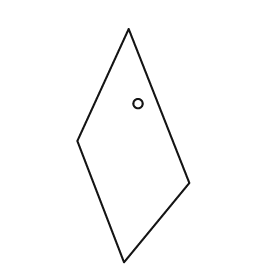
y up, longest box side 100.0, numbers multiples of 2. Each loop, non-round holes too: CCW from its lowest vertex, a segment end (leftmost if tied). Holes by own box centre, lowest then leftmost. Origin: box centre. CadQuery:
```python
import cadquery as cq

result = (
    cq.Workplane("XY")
    .moveTo(-4.0, -50.0)
    .lineTo(24.0, -16.0)
    .lineTo(-2.0, 50.0)
    .lineTo(-24.0, 2.0)
    .close()
    .moveTo(2.0, 18.0)
    .circle(2.0)
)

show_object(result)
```